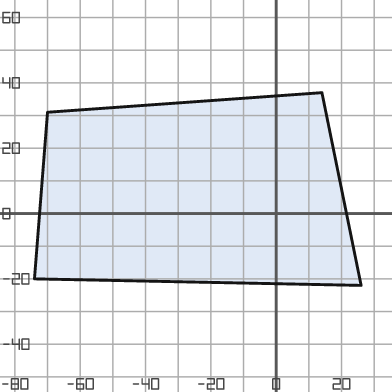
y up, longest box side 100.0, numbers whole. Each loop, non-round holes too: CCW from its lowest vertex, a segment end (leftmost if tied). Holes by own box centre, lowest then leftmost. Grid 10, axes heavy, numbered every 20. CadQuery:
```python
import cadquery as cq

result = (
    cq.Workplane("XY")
    .moveTo(26.0, -22.0)
    .lineTo(14.0, 37.0)
    .lineTo(-70.0, 31.0)
    .lineTo(-74.0, -20.0)
    .close()
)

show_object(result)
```